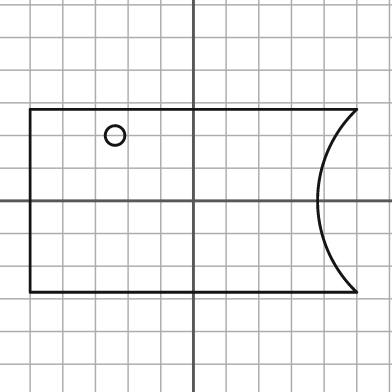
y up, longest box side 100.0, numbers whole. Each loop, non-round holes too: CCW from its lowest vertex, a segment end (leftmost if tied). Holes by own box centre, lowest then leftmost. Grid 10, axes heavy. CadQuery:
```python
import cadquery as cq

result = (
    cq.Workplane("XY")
    .moveTo(-50.0, -28.0)
    .lineTo(50.0, -28.0)
    .threePointArc((38.0, 0.0), (50.0, 28.0))
    .lineTo(-50.0, 28.0)
    .close()
    .moveTo(-24.0, 20.0)
    .circle(3.0)
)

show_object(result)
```